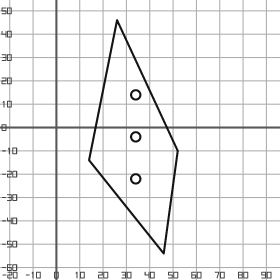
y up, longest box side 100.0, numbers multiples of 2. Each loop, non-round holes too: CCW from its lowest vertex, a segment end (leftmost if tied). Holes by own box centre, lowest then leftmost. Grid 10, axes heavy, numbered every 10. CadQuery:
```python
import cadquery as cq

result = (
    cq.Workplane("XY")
    .moveTo(46.0, -54.0)
    .lineTo(52.0, -10.0)
    .lineTo(26.0, 46.0)
    .lineTo(14.0, -14.0)
    .close()
    .moveTo(34.0, -22.0)
    .circle(2.0)
    .moveTo(34.0, -4.0)
    .circle(2.0)
    .moveTo(34.0, 14.0)
    .circle(2.0)
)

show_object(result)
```